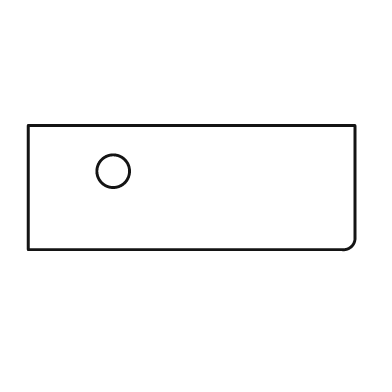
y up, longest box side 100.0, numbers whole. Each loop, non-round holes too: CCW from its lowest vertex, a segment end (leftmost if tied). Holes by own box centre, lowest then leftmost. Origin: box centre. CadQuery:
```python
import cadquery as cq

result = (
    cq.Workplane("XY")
    .moveTo(-50.0, -19.0)
    .lineTo(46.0, -19.0)
    .threePointArc((49.0, -18.0), (50.0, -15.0))
    .lineTo(50.0, 19.0)
    .lineTo(-50.0, 19.0)
    .close()
    .moveTo(-24.0, 5.0)
    .circle(5.0)
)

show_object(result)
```